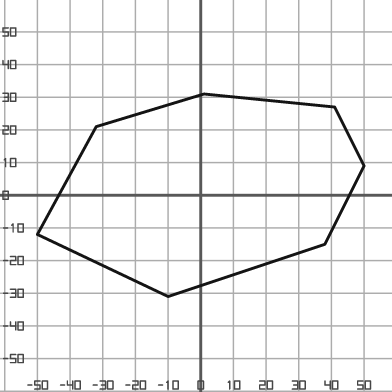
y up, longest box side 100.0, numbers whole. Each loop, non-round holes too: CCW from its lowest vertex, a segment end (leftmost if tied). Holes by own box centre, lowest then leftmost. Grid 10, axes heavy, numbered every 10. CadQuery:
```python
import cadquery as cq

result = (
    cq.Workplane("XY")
    .moveTo(-10.0, -31.0)
    .lineTo(38.0, -15.0)
    .lineTo(50.0, 9.0)
    .lineTo(41.0, 27.0)
    .lineTo(1.0, 31.0)
    .lineTo(-32.0, 21.0)
    .lineTo(-50.0, -12.0)
    .close()
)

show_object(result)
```